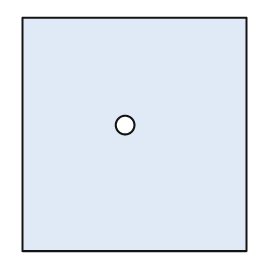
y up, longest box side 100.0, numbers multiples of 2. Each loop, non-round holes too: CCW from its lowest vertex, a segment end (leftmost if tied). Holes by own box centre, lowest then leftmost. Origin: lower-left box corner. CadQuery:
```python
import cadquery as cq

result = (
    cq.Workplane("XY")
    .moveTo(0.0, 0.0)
    .lineTo(96.0, 0.0)
    .lineTo(96.0, 100.0)
    .lineTo(0.0, 100.0)
    .close()
    .moveTo(44.0, 54.0)
    .circle(4.0)
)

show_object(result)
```